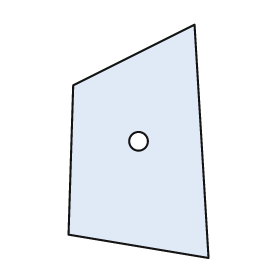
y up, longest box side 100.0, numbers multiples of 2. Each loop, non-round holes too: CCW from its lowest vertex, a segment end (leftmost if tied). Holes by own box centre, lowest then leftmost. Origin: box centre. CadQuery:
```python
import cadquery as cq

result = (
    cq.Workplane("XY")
    .moveTo(30.0, -50.0)
    .lineTo(24.0, 50.0)
    .lineTo(-28.0, 24.0)
    .lineTo(-30.0, -40.0)
    .close()
    .moveTo(0.0, 0.0)
    .circle(4.0)
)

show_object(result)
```